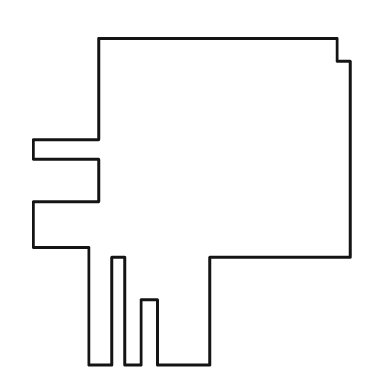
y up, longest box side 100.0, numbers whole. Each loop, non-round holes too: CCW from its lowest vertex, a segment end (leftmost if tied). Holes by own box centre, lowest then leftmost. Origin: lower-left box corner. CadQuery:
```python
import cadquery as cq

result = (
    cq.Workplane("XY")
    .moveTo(17.0, 0.0)
    .lineTo(24.0, 0.0)
    .lineTo(24.0, 33.0)
    .lineTo(28.0, 33.0)
    .lineTo(28.0, 0.0)
    .lineTo(33.0, 0.0)
    .lineTo(33.0, 20.0)
    .lineTo(38.0, 20.0)
    .lineTo(38.0, 0.0)
    .lineTo(54.0, 0.0)
    .lineTo(54.0, 33.0)
    .lineTo(97.0, 33.0)
    .lineTo(97.0, 93.0)
    .lineTo(93.0, 93.0)
    .lineTo(93.0, 100.0)
    .lineTo(20.0, 100.0)
    .lineTo(20.0, 69.0)
    .lineTo(0.0, 69.0)
    .lineTo(0.0, 63.0)
    .lineTo(20.0, 63.0)
    .lineTo(20.0, 50.0)
    .lineTo(0.0, 50.0)
    .lineTo(0.0, 36.0)
    .lineTo(17.0, 36.0)
    .close()
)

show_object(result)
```